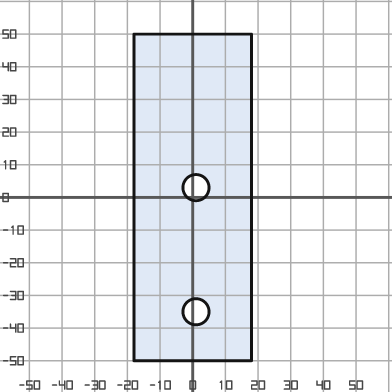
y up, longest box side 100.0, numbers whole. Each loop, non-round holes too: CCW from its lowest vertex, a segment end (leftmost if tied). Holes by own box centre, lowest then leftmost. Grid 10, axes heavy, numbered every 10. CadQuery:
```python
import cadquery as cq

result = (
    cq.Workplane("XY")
    .moveTo(-18.0, -50.0)
    .lineTo(18.0, -50.0)
    .lineTo(18.0, 50.0)
    .lineTo(-18.0, 50.0)
    .close()
    .moveTo(1.0, -35.0)
    .circle(4.0)
    .moveTo(1.0, 3.0)
    .circle(4.0)
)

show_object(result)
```